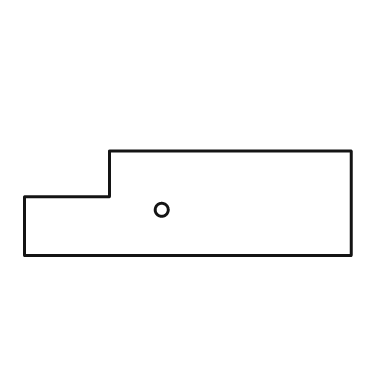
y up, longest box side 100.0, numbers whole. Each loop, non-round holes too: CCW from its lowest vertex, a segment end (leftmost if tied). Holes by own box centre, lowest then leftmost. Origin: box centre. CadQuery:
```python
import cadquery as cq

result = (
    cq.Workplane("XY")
    .moveTo(-50.0, -16.0)
    .lineTo(50.0, -16.0)
    .lineTo(50.0, 16.0)
    .lineTo(-24.0, 16.0)
    .lineTo(-24.0, 2.0)
    .lineTo(-50.0, 2.0)
    .close()
    .moveTo(-8.0, -2.0)
    .circle(2.0)
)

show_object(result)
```